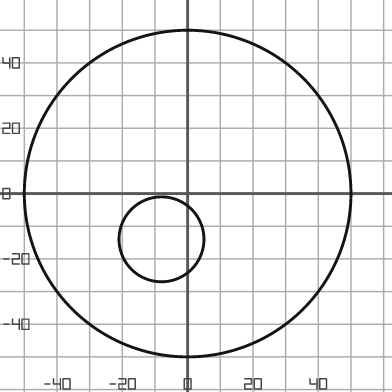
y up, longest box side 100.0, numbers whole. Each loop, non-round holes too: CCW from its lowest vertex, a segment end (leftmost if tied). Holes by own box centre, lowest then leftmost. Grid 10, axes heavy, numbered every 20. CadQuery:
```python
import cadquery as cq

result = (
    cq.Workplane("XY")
    .moveTo(0.0, 0.0)
    .circle(50.0)
    .moveTo(-8.0, -14.0)
    .circle(13.0)
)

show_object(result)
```